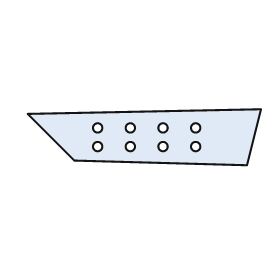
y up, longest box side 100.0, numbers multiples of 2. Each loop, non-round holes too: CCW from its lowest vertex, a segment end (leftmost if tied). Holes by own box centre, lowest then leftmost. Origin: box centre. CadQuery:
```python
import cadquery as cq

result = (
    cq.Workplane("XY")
    .moveTo(44.0, -12.0)
    .lineTo(50.0, 12.0)
    .lineTo(-50.0, 10.0)
    .lineTo(-30.0, -10.0)
    .close()
    .moveTo(-20.0, -4.0)
    .circle(2.0)
    .moveTo(-6.0, -4.0)
    .circle(2.0)
    .moveTo(8.0, -4.0)
    .circle(2.0)
    .moveTo(22.0, -4.0)
    .circle(2.0)
    .moveTo(-20.0, 4.0)
    .circle(2.0)
    .moveTo(-6.0, 4.0)
    .circle(2.0)
    .moveTo(8.0, 4.0)
    .circle(2.0)
    .moveTo(22.0, 4.0)
    .circle(2.0)
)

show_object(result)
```